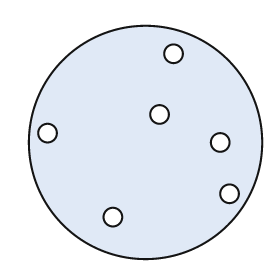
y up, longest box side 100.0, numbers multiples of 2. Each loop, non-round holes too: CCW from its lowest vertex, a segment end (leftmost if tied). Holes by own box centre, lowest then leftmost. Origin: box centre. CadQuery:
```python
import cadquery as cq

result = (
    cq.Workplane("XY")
    .moveTo(0.0, 0.0)
    .circle(50.0)
    .moveTo(-14.0, -32.0)
    .circle(4.0)
    .moveTo(36.0, -22.0)
    .circle(4.0)
    .moveTo(32.0, 0.0)
    .circle(4.0)
    .moveTo(-42.0, 4.0)
    .circle(4.0)
    .moveTo(6.0, 12.0)
    .circle(4.0)
    .moveTo(12.0, 38.0)
    .circle(4.0)
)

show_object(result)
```